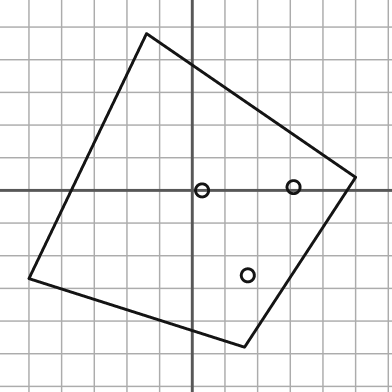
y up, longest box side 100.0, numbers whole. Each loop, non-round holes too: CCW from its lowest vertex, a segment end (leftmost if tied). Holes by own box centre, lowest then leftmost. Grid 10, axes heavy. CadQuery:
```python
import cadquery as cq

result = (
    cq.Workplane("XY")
    .moveTo(16.0, -48.0)
    .lineTo(50.0, 4.0)
    .lineTo(-14.0, 48.0)
    .lineTo(-50.0, -27.0)
    .close()
    .moveTo(17.0, -26.0)
    .circle(2.0)
    .moveTo(3.0, 0.0)
    .circle(2.0)
    .moveTo(31.0, 1.0)
    .circle(2.0)
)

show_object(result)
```